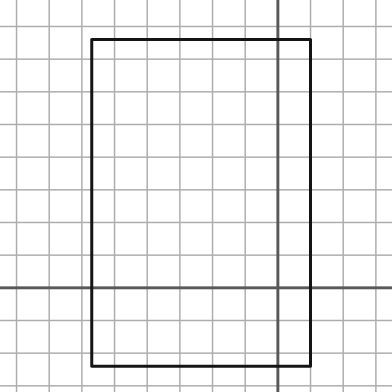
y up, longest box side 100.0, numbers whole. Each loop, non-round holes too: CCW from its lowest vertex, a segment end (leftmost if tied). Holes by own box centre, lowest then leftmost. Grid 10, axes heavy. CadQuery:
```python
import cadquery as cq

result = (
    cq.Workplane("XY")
    .moveTo(-57.0, -24.0)
    .lineTo(10.0, -24.0)
    .lineTo(10.0, 76.0)
    .lineTo(-57.0, 76.0)
    .close()
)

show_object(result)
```